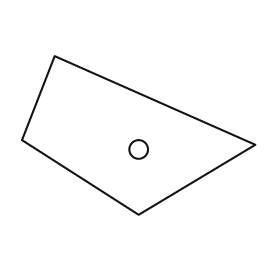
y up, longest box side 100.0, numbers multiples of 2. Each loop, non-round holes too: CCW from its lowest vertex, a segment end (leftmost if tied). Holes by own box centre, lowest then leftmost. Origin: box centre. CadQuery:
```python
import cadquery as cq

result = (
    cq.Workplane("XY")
    .moveTo(0.0, -34.0)
    .lineTo(50.0, -4.0)
    .lineTo(-36.0, 34.0)
    .lineTo(-50.0, -2.0)
    .close()
    .moveTo(0.0, -6.0)
    .circle(4.0)
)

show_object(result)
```